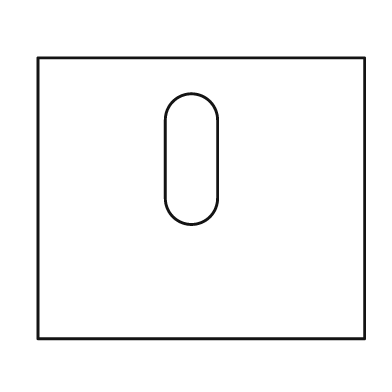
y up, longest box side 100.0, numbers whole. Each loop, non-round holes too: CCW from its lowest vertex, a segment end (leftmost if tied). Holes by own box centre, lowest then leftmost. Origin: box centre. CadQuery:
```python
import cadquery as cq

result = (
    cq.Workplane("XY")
    .moveTo(-50.0, -43.0)
    .lineTo(50.0, -43.0)
    .lineTo(50.0, 43.0)
    .lineTo(-50.0, 43.0)
    .close()
    .moveTo(-11.0, 0.0)
    .threePointArc((-3.0, -8.0), (5.0, 0.0))
    .lineTo(5.0, 24.0)
    .threePointArc((-3.0, 32.0), (-11.0, 24.0))
    .close()
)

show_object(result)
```